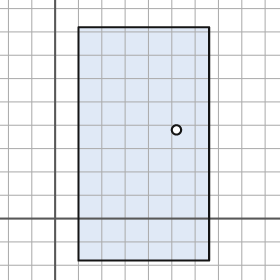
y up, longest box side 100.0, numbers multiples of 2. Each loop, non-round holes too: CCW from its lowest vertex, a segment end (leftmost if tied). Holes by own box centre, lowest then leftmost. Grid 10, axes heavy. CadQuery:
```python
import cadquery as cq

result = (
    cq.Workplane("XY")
    .moveTo(10.0, -18.0)
    .lineTo(66.0, -18.0)
    .lineTo(66.0, 82.0)
    .lineTo(10.0, 82.0)
    .close()
    .moveTo(52.0, 38.0)
    .circle(2.0)
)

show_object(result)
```